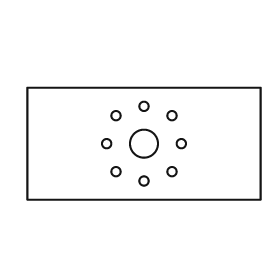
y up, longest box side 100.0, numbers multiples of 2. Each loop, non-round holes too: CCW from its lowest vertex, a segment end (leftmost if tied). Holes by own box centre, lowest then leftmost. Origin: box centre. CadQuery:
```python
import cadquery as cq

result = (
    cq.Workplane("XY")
    .moveTo(-50.0, -24.0)
    .lineTo(50.0, -24.0)
    .lineTo(50.0, 24.0)
    .lineTo(-50.0, 24.0)
    .close()
    .moveTo(0.0, -16.0)
    .circle(2.0)
    .moveTo(-12.0, -12.0)
    .circle(2.0)
    .moveTo(12.0, -12.0)
    .circle(2.0)
    .moveTo(-16.0, 0.0)
    .circle(2.0)
    .moveTo(0.0, 0.0)
    .circle(6.0)
    .moveTo(16.0, 0.0)
    .circle(2.0)
    .moveTo(-12.0, 12.0)
    .circle(2.0)
    .moveTo(12.0, 12.0)
    .circle(2.0)
    .moveTo(0.0, 16.0)
    .circle(2.0)
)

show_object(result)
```